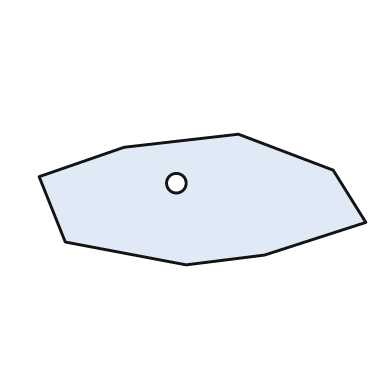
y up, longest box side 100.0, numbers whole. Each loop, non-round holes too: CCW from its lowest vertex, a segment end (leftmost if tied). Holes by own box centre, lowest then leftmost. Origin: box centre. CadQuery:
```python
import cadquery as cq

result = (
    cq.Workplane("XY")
    .moveTo(-5.0, -20.0)
    .lineTo(19.0, -17.0)
    .lineTo(50.0, -7.0)
    .lineTo(40.0, 9.0)
    .lineTo(11.0, 20.0)
    .lineTo(-24.0, 16.0)
    .lineTo(-50.0, 7.0)
    .lineTo(-42.0, -13.0)
    .close()
    .moveTo(-8.0, 5.0)
    .circle(3.0)
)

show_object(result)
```